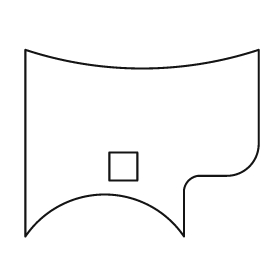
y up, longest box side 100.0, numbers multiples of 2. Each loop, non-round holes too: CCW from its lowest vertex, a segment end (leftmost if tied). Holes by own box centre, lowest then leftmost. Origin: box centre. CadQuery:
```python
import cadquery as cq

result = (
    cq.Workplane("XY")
    .moveTo(-50.0, -40.0)
    .threePointArc((-16.0, -22.0), (18.0, -40.0))
    .lineTo(18.0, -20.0)
    .threePointArc((20.0, -16.0), (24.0, -14.0))
    .lineTo(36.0, -14.0)
    .threePointArc((46.0, -10.0), (50.0, 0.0))
    .lineTo(50.0, 40.0)
    .threePointArc((0.0, 32.0), (-50.0, 40.0))
    .close()
    .moveTo(-14.0, -16.0)
    .lineTo(-2.0, -16.0)
    .lineTo(-2.0, -4.0)
    .lineTo(-14.0, -4.0)
    .close()
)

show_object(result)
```